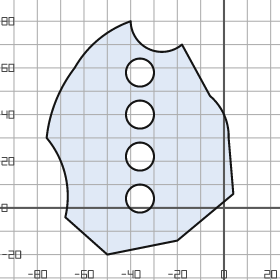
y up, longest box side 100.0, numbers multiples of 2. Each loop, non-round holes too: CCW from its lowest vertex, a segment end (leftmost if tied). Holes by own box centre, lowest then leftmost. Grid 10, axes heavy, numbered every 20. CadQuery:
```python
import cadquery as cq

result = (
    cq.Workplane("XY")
    .moveTo(-50.0, -20.0)
    .lineTo(-20.0, -14.0)
    .lineTo(4.0, 6.0)
    .lineTo(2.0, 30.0)
    .threePointArc((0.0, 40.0), (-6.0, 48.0))
    .lineTo(-18.0, 70.0)
    .threePointArc((-32.0, 68.0), (-40.0, 80.0))
    .threePointArc((-54.0, 72.0), (-64.0, 60.0))
    .threePointArc((-72.0, 46.0), (-76.0, 30.0))
    .threePointArc((-68.0, 14.0), (-68.0, -4.0))
    .close()
    .moveTo(-36.0, 4.0)
    .circle(6.0)
    .moveTo(-36.0, 22.0)
    .circle(6.0)
    .moveTo(-36.0, 40.0)
    .circle(6.0)
    .moveTo(-36.0, 58.0)
    .circle(6.0)
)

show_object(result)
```